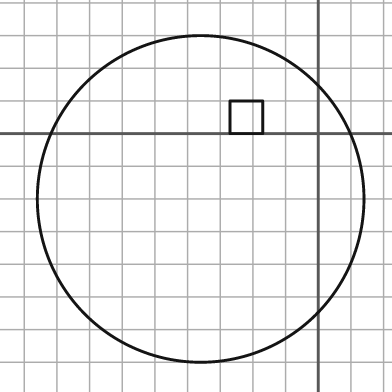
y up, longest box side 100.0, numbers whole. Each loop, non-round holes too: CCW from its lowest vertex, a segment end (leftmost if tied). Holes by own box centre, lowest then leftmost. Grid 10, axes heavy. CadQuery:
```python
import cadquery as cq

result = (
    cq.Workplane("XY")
    .moveTo(-36.0, -20.0)
    .circle(50.0)
    .moveTo(-27.0, 0.0)
    .lineTo(-17.0, 0.0)
    .lineTo(-17.0, 10.0)
    .lineTo(-27.0, 10.0)
    .close()
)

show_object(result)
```